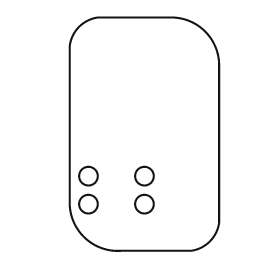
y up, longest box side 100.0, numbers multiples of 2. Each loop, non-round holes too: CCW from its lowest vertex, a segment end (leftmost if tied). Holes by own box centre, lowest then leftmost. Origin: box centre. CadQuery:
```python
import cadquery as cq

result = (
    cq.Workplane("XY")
    .moveTo(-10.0, -50.0)
    .lineTo(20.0, -50.0)
    .threePointArc((28.0, -46.0), (32.0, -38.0))
    .lineTo(32.0, 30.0)
    .threePointArc((26.0, 44.0), (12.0, 50.0))
    .lineTo(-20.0, 50.0)
    .threePointArc((-28.0, 46.0), (-32.0, 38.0))
    .lineTo(-32.0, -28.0)
    .threePointArc((-26.0, -44.0), (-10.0, -50.0))
    .close()
    .moveTo(-24.0, -30.0)
    .circle(4.0)
    .moveTo(0.0, -30.0)
    .circle(4.0)
    .moveTo(-24.0, -18.0)
    .circle(4.0)
    .moveTo(0.0, -18.0)
    .circle(4.0)
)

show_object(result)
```